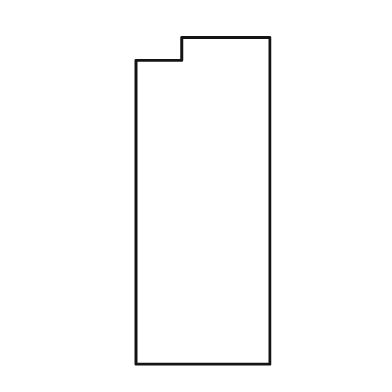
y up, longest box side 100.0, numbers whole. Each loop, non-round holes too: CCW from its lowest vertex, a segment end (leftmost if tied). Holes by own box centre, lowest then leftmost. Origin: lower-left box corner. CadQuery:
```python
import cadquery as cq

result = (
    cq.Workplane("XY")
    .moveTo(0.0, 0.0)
    .lineTo(41.0, 0.0)
    .lineTo(41.0, 100.0)
    .lineTo(14.0, 100.0)
    .lineTo(14.0, 93.0)
    .lineTo(0.0, 93.0)
    .close()
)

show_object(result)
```